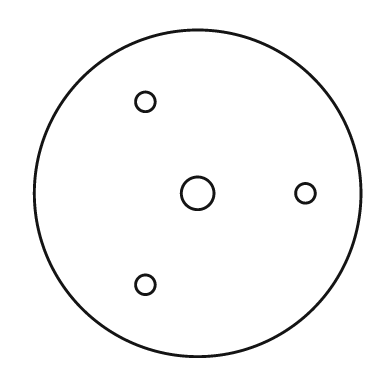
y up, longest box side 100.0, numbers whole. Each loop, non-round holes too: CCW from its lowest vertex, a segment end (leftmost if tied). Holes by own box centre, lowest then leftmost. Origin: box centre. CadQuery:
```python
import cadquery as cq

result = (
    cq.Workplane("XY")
    .moveTo(0.0, 0.0)
    .circle(50.0)
    .moveTo(-16.0, -28.0)
    .circle(3.0)
    .moveTo(0.0, 0.0)
    .circle(5.0)
    .moveTo(33.0, 0.0)
    .circle(3.0)
    .moveTo(-16.0, 28.0)
    .circle(3.0)
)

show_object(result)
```